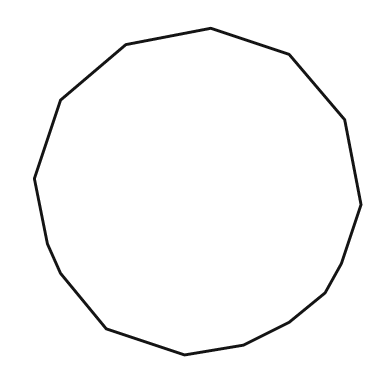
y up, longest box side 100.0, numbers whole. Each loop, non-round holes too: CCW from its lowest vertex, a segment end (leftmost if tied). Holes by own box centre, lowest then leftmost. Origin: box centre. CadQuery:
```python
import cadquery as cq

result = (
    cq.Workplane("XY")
    .moveTo(-4.0, -50.0)
    .lineTo(14.0, -47.0)
    .lineTo(28.0, -40.0)
    .lineTo(39.0, -31.0)
    .lineTo(44.0, -22.0)
    .lineTo(50.0, -4.0)
    .lineTo(45.0, 22.0)
    .lineTo(28.0, 42.0)
    .lineTo(4.0, 50.0)
    .lineTo(-22.0, 45.0)
    .lineTo(-42.0, 28.0)
    .lineTo(-50.0, 4.0)
    .lineTo(-46.0, -16.0)
    .lineTo(-42.0, -25.0)
    .lineTo(-28.0, -42.0)
    .close()
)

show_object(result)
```